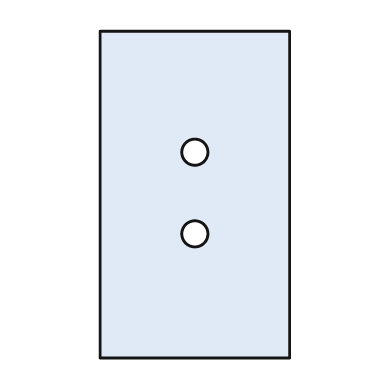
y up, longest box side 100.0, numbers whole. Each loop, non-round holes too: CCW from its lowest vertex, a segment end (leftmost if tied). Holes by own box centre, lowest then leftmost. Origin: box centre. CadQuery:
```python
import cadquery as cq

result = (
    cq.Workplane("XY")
    .moveTo(-29.0, -50.0)
    .lineTo(29.0, -50.0)
    .lineTo(29.0, 50.0)
    .lineTo(-29.0, 50.0)
    .close()
    .moveTo(0.0, -12.0)
    .circle(4.0)
    .moveTo(0.0, 13.0)
    .circle(4.0)
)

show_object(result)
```